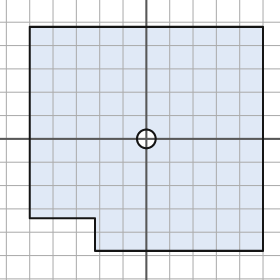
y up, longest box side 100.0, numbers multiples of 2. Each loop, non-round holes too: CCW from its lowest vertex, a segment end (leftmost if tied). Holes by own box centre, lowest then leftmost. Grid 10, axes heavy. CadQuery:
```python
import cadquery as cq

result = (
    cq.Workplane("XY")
    .moveTo(-22.0, -48.0)
    .lineTo(50.0, -48.0)
    .lineTo(50.0, 48.0)
    .lineTo(-50.0, 48.0)
    .lineTo(-50.0, -34.0)
    .lineTo(-22.0, -34.0)
    .close()
    .moveTo(0.0, 0.0)
    .circle(4.0)
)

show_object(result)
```